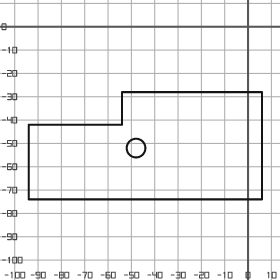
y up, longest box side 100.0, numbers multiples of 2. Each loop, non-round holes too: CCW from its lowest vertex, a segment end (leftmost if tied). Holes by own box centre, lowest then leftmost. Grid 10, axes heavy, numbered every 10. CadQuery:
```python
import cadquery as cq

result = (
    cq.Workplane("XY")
    .moveTo(-94.0, -74.0)
    .lineTo(6.0, -74.0)
    .lineTo(6.0, -28.0)
    .lineTo(-54.0, -28.0)
    .lineTo(-54.0, -42.0)
    .lineTo(-94.0, -42.0)
    .close()
    .moveTo(-48.0, -52.0)
    .circle(4.0)
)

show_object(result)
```